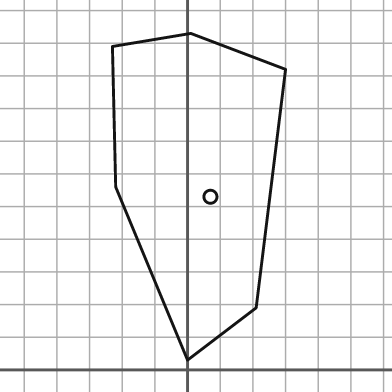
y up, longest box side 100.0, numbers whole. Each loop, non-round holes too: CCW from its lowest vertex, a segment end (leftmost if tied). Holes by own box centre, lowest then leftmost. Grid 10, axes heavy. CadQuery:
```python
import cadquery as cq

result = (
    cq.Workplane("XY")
    .moveTo(0.0, 3.0)
    .lineTo(21.0, 19.0)
    .lineTo(30.0, 92.0)
    .lineTo(1.0, 103.0)
    .lineTo(-23.0, 99.0)
    .lineTo(-22.0, 56.0)
    .close()
    .moveTo(7.0, 53.0)
    .circle(2.0)
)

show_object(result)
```